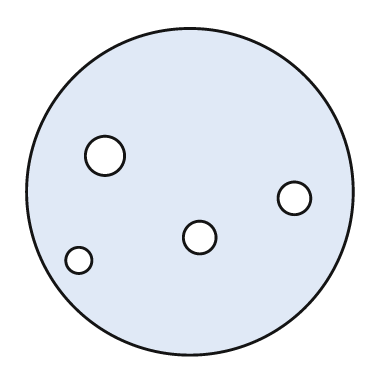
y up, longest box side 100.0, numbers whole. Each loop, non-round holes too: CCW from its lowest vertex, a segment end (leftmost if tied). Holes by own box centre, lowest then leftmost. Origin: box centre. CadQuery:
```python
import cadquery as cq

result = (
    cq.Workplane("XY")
    .moveTo(0.0, 0.0)
    .circle(50.0)
    .moveTo(-34.0, -21.0)
    .circle(4.0)
    .moveTo(3.0, -14.0)
    .circle(5.0)
    .moveTo(32.0, -2.0)
    .circle(5.0)
    .moveTo(-26.0, 11.0)
    .circle(6.0)
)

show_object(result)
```